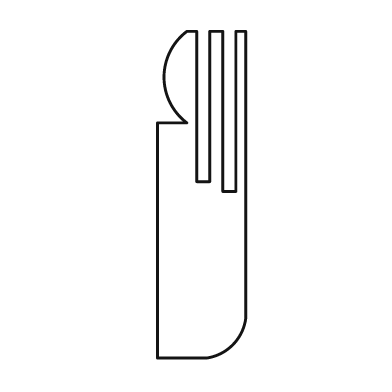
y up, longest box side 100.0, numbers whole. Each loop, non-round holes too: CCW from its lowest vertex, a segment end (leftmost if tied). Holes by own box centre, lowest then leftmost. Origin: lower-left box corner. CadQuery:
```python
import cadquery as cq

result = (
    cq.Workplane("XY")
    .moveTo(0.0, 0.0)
    .lineTo(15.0, 0.0)
    .threePointArc((23.0, 4.0), (27.0, 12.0))
    .lineTo(27.0, 100.0)
    .lineTo(24.0, 100.0)
    .lineTo(24.0, 51.0)
    .lineTo(20.0, 51.0)
    .lineTo(20.0, 100.0)
    .lineTo(16.0, 100.0)
    .lineTo(16.0, 54.0)
    .lineTo(12.0, 54.0)
    .lineTo(12.0, 100.0)
    .lineTo(9.0, 100.0)
    .threePointArc((2.0, 86.0), (9.0, 72.0))
    .lineTo(0.0, 72.0)
    .close()
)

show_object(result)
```